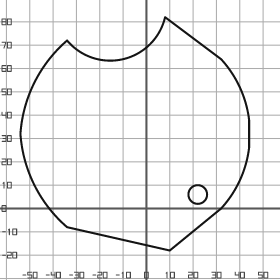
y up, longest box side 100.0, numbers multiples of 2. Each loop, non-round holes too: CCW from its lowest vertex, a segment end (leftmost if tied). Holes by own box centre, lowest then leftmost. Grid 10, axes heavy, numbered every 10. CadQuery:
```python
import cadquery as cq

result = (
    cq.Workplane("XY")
    .moveTo(10.0, -18.0)
    .lineTo(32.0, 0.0)
    .threePointArc((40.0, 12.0), (44.0, 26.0))
    .lineTo(44.0, 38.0)
    .threePointArc((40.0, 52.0), (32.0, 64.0))
    .lineTo(8.0, 82.0)
    .threePointArc((-10.0, 64.0), (-34.0, 72.0))
    .threePointArc((-48.0, 54.0), (-54.0, 32.0))
    .threePointArc((-48.0, 10.0), (-34.0, -8.0))
    .close()
    .moveTo(22.0, 6.0)
    .circle(4.0)
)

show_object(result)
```